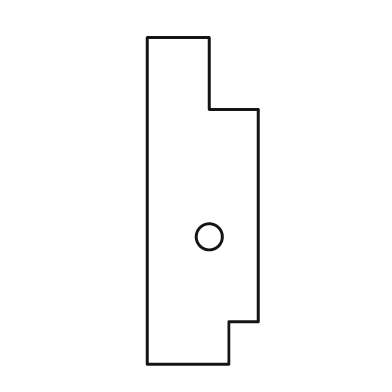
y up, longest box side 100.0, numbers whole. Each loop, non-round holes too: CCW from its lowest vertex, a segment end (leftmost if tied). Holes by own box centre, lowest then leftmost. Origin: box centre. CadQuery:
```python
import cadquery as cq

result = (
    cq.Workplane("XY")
    .moveTo(-17.0, -50.0)
    .lineTo(8.0, -50.0)
    .lineTo(8.0, -37.0)
    .lineTo(17.0, -37.0)
    .lineTo(17.0, 28.0)
    .lineTo(2.0, 28.0)
    .lineTo(2.0, 50.0)
    .lineTo(-17.0, 50.0)
    .close()
    .moveTo(2.0, -11.0)
    .circle(4.0)
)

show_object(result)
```